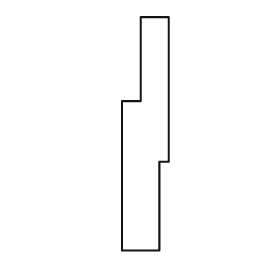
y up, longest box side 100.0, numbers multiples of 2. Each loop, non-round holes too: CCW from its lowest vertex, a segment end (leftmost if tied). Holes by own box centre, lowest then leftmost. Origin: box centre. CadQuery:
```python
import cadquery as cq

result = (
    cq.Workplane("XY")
    .moveTo(-10.0, -50.0)
    .lineTo(6.0, -50.0)
    .lineTo(6.0, -12.0)
    .lineTo(10.0, -12.0)
    .lineTo(10.0, 50.0)
    .lineTo(-2.0, 50.0)
    .lineTo(-2.0, 14.0)
    .lineTo(-10.0, 14.0)
    .close()
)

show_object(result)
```